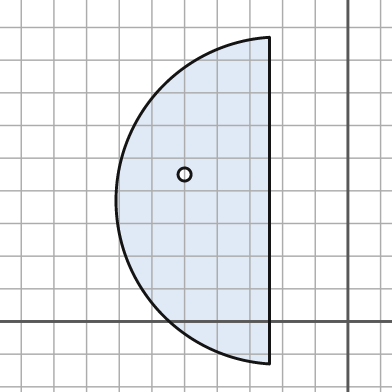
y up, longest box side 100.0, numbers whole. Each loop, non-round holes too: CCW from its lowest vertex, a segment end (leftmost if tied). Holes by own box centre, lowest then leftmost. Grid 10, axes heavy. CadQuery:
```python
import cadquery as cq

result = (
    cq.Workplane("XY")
    .moveTo(-24.0, -13.0)
    .lineTo(-24.0, 87.0)
    .threePointArc((-71.0, 37.0), (-24.0, -13.0))
    .close()
    .moveTo(-50.0, 45.0)
    .circle(2.0)
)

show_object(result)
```